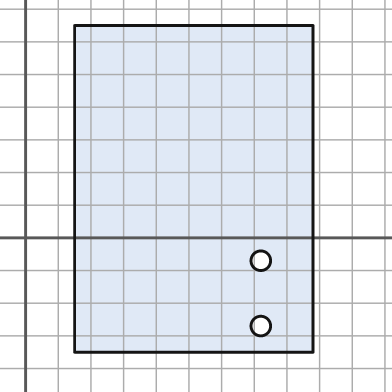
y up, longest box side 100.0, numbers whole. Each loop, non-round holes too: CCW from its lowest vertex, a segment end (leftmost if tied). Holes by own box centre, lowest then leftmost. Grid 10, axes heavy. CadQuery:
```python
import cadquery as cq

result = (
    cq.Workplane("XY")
    .moveTo(15.0, -35.0)
    .lineTo(88.0, -35.0)
    .lineTo(88.0, 65.0)
    .lineTo(15.0, 65.0)
    .close()
    .moveTo(72.0, -27.0)
    .circle(3.0)
    .moveTo(72.0, -7.0)
    .circle(3.0)
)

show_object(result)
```